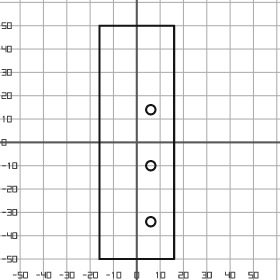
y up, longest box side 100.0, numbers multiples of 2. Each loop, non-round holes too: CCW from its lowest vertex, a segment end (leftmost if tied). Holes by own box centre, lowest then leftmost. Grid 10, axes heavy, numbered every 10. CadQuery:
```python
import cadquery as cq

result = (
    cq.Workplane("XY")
    .moveTo(-16.0, -50.0)
    .lineTo(16.0, -50.0)
    .lineTo(16.0, 50.0)
    .lineTo(-16.0, 50.0)
    .close()
    .moveTo(6.0, -34.0)
    .circle(2.0)
    .moveTo(6.0, -10.0)
    .circle(2.0)
    .moveTo(6.0, 14.0)
    .circle(2.0)
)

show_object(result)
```